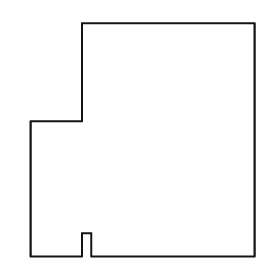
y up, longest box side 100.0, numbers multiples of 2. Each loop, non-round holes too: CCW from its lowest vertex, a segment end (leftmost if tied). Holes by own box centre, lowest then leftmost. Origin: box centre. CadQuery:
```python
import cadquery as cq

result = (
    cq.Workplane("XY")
    .moveTo(-48.0, -50.0)
    .lineTo(-26.0, -50.0)
    .lineTo(-26.0, -40.0)
    .lineTo(-22.0, -40.0)
    .lineTo(-22.0, -50.0)
    .lineTo(48.0, -50.0)
    .lineTo(48.0, 50.0)
    .lineTo(-26.0, 50.0)
    .lineTo(-26.0, 8.0)
    .lineTo(-48.0, 8.0)
    .close()
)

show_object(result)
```